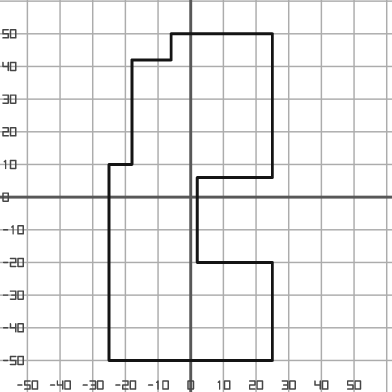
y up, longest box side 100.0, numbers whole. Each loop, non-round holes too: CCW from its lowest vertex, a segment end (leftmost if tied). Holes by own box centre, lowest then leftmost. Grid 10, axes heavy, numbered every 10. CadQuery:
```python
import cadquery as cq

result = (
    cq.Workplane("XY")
    .moveTo(-25.0, -50.0)
    .lineTo(25.0, -50.0)
    .lineTo(25.0, -20.0)
    .lineTo(2.0, -20.0)
    .lineTo(2.0, 6.0)
    .lineTo(25.0, 6.0)
    .lineTo(25.0, 50.0)
    .lineTo(-6.0, 50.0)
    .lineTo(-6.0, 42.0)
    .lineTo(-18.0, 42.0)
    .lineTo(-18.0, 10.0)
    .lineTo(-25.0, 10.0)
    .close()
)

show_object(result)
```